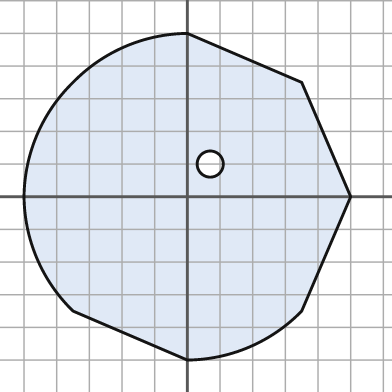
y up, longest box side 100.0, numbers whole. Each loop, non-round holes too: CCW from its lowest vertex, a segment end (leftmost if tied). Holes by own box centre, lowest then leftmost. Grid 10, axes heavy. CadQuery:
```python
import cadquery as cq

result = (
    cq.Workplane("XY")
    .moveTo(0.0, -50.0)
    .threePointArc((19.0, -46.0), (35.0, -35.0))
    .lineTo(50.0, 0.0)
    .lineTo(35.0, 35.0)
    .lineTo(0.0, 50.0)
    .threePointArc((-19.0, 46.0), (-35.0, 35.0))
    .threePointArc((-46.0, 19.0), (-50.0, 0.0))
    .threePointArc((-46.0, -19.0), (-35.0, -35.0))
    .close()
    .moveTo(7.0, 10.0)
    .circle(4.0)
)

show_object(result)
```